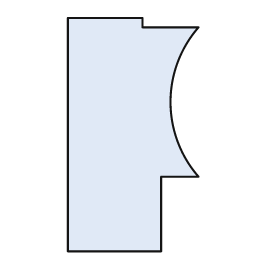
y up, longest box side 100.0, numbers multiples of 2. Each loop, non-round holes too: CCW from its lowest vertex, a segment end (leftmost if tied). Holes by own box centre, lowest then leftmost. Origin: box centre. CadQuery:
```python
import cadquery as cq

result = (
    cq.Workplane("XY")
    .moveTo(-28.0, -50.0)
    .lineTo(12.0, -50.0)
    .lineTo(12.0, -18.0)
    .lineTo(28.0, -18.0)
    .threePointArc((16.0, 14.0), (28.0, 46.0))
    .lineTo(4.0, 46.0)
    .lineTo(4.0, 50.0)
    .lineTo(-28.0, 50.0)
    .close()
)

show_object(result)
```